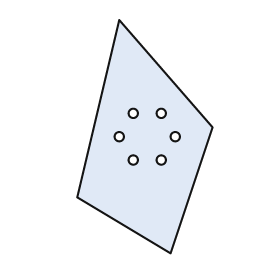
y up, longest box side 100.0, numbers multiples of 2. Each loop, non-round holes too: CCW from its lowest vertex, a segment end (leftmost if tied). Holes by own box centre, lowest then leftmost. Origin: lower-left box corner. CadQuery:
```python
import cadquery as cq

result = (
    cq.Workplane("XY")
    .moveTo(40.0, 0.0)
    .lineTo(58.0, 54.0)
    .lineTo(18.0, 100.0)
    .lineTo(0.0, 24.0)
    .close()
    .moveTo(24.0, 40.0)
    .circle(2.0)
    .moveTo(36.0, 40.0)
    .circle(2.0)
    .moveTo(18.0, 50.0)
    .circle(2.0)
    .moveTo(42.0, 50.0)
    .circle(2.0)
    .moveTo(24.0, 60.0)
    .circle(2.0)
    .moveTo(36.0, 60.0)
    .circle(2.0)
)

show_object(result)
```